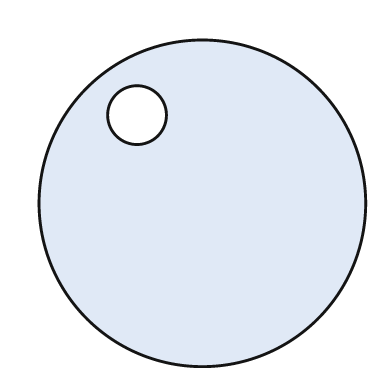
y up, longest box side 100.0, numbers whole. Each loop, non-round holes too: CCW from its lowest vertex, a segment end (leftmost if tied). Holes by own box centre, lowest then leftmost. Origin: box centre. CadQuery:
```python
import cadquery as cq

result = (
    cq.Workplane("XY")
    .moveTo(0.0, 0.0)
    .circle(50.0)
    .moveTo(-20.0, 27.0)
    .circle(9.0)
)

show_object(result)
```